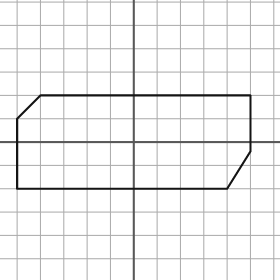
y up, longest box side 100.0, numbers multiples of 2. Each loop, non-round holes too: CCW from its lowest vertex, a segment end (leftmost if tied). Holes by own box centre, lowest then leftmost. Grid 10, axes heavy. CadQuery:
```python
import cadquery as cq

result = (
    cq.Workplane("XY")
    .moveTo(-50.0, -20.0)
    .lineTo(40.0, -20.0)
    .lineTo(50.0, -4.0)
    .lineTo(50.0, 20.0)
    .lineTo(-40.0, 20.0)
    .lineTo(-50.0, 10.0)
    .close()
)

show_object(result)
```